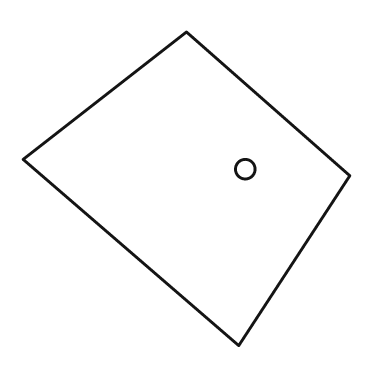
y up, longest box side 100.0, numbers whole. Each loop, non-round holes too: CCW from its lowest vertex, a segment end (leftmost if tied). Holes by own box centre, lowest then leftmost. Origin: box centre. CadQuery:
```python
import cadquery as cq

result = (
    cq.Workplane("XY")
    .moveTo(16.0, -48.0)
    .lineTo(50.0, 4.0)
    .lineTo(0.0, 48.0)
    .lineTo(-50.0, 9.0)
    .close()
    .moveTo(18.0, 6.0)
    .circle(3.0)
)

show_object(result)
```